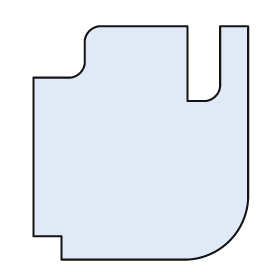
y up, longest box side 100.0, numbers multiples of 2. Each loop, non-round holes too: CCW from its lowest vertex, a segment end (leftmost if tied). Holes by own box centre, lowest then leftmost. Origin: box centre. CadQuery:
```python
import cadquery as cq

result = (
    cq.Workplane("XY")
    .moveTo(-34.0, -50.0)
    .lineTo(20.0, -50.0)
    .threePointArc((38.0, -42.0), (46.0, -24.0))
    .lineTo(46.0, 50.0)
    .lineTo(34.0, 50.0)
    .lineTo(34.0, 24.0)
    .threePointArc((32.0, 20.0), (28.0, 18.0))
    .lineTo(20.0, 18.0)
    .lineTo(20.0, 50.0)
    .lineTo(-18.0, 50.0)
    .threePointArc((-22.0, 48.0), (-24.0, 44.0))
    .lineTo(-24.0, 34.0)
    .threePointArc((-26.0, 30.0), (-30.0, 28.0))
    .lineTo(-46.0, 28.0)
    .lineTo(-46.0, -40.0)
    .lineTo(-34.0, -40.0)
    .close()
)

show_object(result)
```